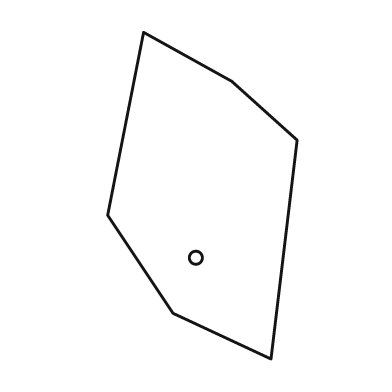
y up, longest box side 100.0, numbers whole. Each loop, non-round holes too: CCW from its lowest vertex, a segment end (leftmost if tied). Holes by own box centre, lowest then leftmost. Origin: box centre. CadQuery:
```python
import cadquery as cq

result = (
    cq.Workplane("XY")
    .moveTo(21.0, -50.0)
    .lineTo(29.0, 17.0)
    .lineTo(9.0, 35.0)
    .lineTo(-18.0, 50.0)
    .lineTo(-29.0, -6.0)
    .lineTo(-9.0, -36.0)
    .close()
    .moveTo(-2.0, -19.0)
    .circle(2.0)
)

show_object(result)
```